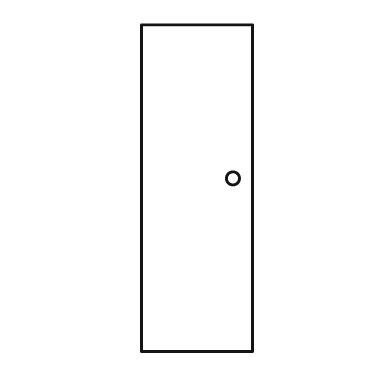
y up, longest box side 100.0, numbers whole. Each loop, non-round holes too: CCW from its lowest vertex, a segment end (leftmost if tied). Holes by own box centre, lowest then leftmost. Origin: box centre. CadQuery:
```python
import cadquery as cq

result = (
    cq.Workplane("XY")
    .moveTo(-17.0, -50.0)
    .lineTo(17.0, -50.0)
    .lineTo(17.0, 50.0)
    .lineTo(-17.0, 50.0)
    .close()
    .moveTo(11.0, 3.0)
    .circle(2.0)
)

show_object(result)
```